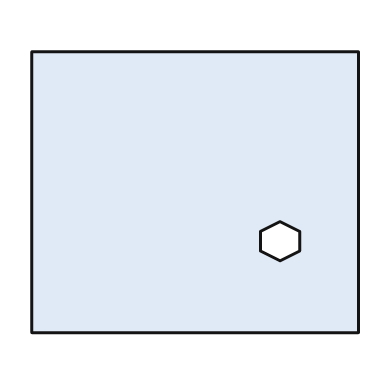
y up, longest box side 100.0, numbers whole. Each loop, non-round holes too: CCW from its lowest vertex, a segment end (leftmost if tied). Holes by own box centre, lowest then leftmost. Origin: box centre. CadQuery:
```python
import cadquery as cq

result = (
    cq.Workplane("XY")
    .moveTo(-50.0, -43.0)
    .lineTo(50.0, -43.0)
    .lineTo(50.0, 43.0)
    .lineTo(-50.0, 43.0)
    .close()
    .moveTo(26.0, -21.0)
    .lineTo(32.0, -18.0)
    .lineTo(32.0, -12.0)
    .lineTo(26.0, -9.0)
    .lineTo(20.0, -12.0)
    .lineTo(20.0, -18.0)
    .close()
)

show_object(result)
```